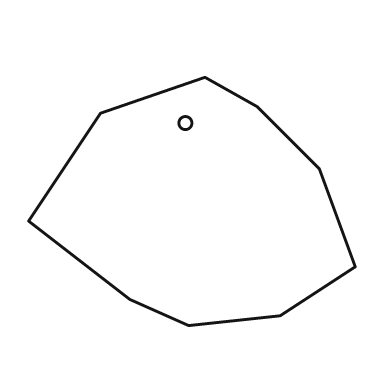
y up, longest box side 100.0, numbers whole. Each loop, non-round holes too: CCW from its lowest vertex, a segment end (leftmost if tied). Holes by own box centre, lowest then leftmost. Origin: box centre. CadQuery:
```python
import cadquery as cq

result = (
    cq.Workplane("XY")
    .moveTo(-1.0, -38.0)
    .lineTo(27.0, -35.0)
    .lineTo(50.0, -20.0)
    .lineTo(39.0, 10.0)
    .lineTo(20.0, 29.0)
    .lineTo(4.0, 38.0)
    .lineTo(-28.0, 27.0)
    .lineTo(-50.0, -6.0)
    .lineTo(-19.0, -30.0)
    .close()
    .moveTo(-2.0, 24.0)
    .circle(2.0)
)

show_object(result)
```